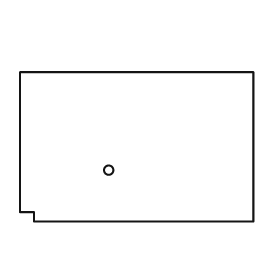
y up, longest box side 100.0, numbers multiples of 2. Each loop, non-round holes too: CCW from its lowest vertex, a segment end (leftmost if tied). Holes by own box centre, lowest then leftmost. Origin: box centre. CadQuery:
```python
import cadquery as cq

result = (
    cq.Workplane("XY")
    .moveTo(-44.0, -32.0)
    .lineTo(50.0, -32.0)
    .lineTo(50.0, 32.0)
    .lineTo(-50.0, 32.0)
    .lineTo(-50.0, -28.0)
    .lineTo(-44.0, -28.0)
    .close()
    .moveTo(-12.0, -10.0)
    .circle(2.0)
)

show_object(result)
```